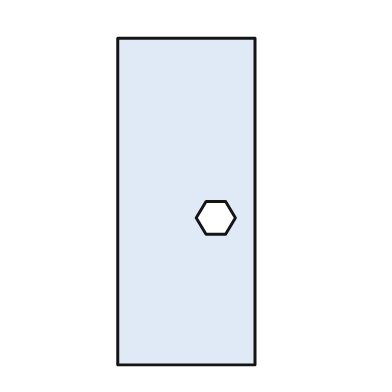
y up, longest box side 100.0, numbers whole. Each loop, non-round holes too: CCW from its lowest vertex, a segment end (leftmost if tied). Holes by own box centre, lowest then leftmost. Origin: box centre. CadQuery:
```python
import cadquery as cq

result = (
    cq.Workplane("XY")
    .moveTo(-21.0, -50.0)
    .lineTo(21.0, -50.0)
    .lineTo(21.0, 50.0)
    .lineTo(-21.0, 50.0)
    .close()
    .moveTo(6.0, -10.0)
    .lineTo(12.0, -10.0)
    .lineTo(15.0, -5.0)
    .lineTo(12.0, 0.0)
    .lineTo(6.0, 0.0)
    .lineTo(3.0, -5.0)
    .close()
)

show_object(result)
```